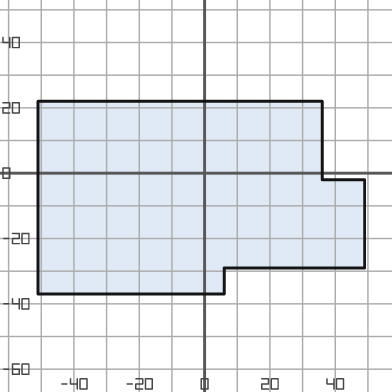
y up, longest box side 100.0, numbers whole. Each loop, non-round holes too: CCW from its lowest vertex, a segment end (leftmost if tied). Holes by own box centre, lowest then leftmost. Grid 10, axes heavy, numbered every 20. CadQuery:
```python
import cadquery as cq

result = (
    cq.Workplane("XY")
    .moveTo(-51.0, -37.0)
    .lineTo(6.0, -37.0)
    .lineTo(6.0, -29.0)
    .lineTo(49.0, -29.0)
    .lineTo(49.0, -2.0)
    .lineTo(36.0, -2.0)
    .lineTo(36.0, 22.0)
    .lineTo(-51.0, 22.0)
    .close()
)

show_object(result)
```